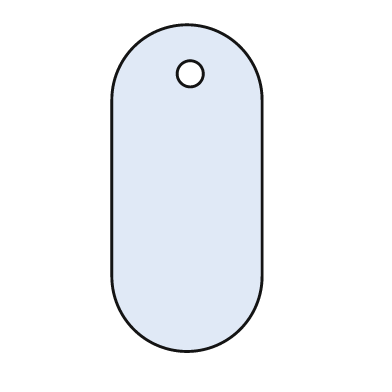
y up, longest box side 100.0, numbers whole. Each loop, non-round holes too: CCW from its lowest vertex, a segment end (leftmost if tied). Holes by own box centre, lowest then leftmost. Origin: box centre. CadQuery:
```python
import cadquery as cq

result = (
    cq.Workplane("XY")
    .moveTo(-23.0, -27.0)
    .threePointArc((0.0, -50.0), (23.0, -27.0))
    .lineTo(23.0, 27.0)
    .threePointArc((0.0, 50.0), (-23.0, 27.0))
    .close()
    .moveTo(1.0, 35.0)
    .circle(4.0)
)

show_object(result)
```